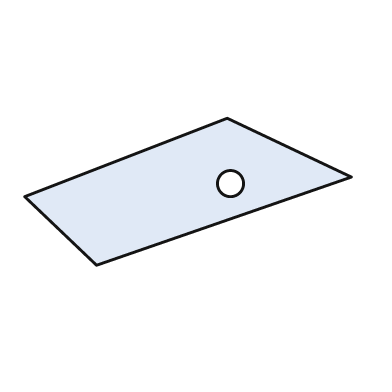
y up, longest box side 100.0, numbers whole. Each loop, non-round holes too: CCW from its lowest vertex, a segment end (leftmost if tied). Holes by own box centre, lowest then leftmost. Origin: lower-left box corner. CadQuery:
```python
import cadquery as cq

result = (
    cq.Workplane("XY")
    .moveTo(22.0, 0.0)
    .lineTo(100.0, 27.0)
    .lineTo(62.0, 45.0)
    .lineTo(0.0, 21.0)
    .close()
    .moveTo(63.0, 25.0)
    .circle(4.0)
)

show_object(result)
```